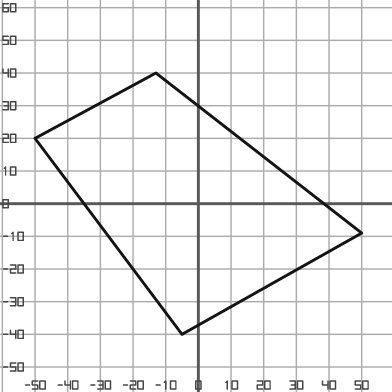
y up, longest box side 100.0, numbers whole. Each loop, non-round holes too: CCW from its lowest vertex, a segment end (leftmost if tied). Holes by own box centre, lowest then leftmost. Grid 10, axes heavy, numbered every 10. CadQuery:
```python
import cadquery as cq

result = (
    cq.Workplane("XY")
    .moveTo(-5.0, -40.0)
    .lineTo(50.0, -9.0)
    .lineTo(-13.0, 40.0)
    .lineTo(-50.0, 20.0)
    .close()
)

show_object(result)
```